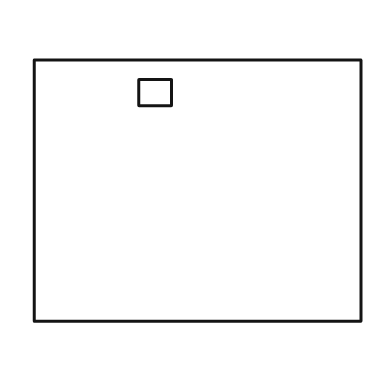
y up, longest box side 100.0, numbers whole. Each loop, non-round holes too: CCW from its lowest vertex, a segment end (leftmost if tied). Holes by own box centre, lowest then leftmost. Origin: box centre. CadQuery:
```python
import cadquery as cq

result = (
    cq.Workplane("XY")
    .moveTo(-50.0, -40.0)
    .lineTo(50.0, -40.0)
    .lineTo(50.0, 40.0)
    .lineTo(-50.0, 40.0)
    .close()
    .moveTo(-18.0, 26.0)
    .lineTo(-8.0, 26.0)
    .lineTo(-8.0, 34.0)
    .lineTo(-18.0, 34.0)
    .close()
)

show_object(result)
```